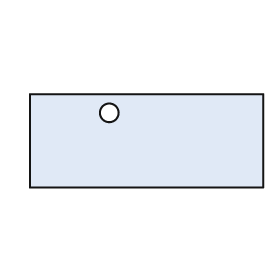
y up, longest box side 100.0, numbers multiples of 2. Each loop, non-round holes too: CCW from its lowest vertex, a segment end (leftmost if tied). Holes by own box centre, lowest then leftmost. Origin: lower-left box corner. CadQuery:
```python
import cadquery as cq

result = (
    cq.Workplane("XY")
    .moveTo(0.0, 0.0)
    .lineTo(100.0, 0.0)
    .lineTo(100.0, 40.0)
    .lineTo(0.0, 40.0)
    .close()
    .moveTo(34.0, 32.0)
    .circle(4.0)
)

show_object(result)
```